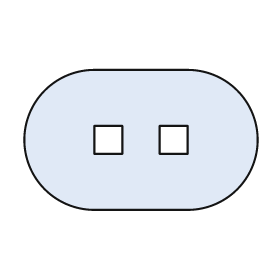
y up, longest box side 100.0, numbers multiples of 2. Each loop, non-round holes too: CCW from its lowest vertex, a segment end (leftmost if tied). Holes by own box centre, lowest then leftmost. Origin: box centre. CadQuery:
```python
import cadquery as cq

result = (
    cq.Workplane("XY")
    .moveTo(-20.0, -30.0)
    .lineTo(20.0, -30.0)
    .threePointArc((50.0, 0.0), (20.0, 30.0))
    .lineTo(-20.0, 30.0)
    .threePointArc((-50.0, 0.0), (-20.0, -30.0))
    .close()
    .moveTo(-20.0, -6.0)
    .lineTo(-8.0, -6.0)
    .lineTo(-8.0, 6.0)
    .lineTo(-20.0, 6.0)
    .close()
    .moveTo(8.0, -6.0)
    .lineTo(20.0, -6.0)
    .lineTo(20.0, 6.0)
    .lineTo(8.0, 6.0)
    .close()
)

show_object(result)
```